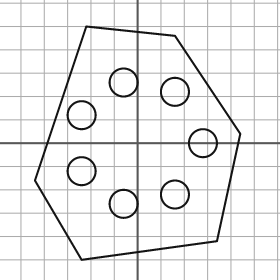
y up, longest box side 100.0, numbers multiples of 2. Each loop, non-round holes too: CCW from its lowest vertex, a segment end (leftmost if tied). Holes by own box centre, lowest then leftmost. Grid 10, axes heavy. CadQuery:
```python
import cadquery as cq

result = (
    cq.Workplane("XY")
    .moveTo(-24.0, -50.0)
    .lineTo(34.0, -42.0)
    .lineTo(44.0, 4.0)
    .lineTo(16.0, 46.0)
    .lineTo(-22.0, 50.0)
    .lineTo(-44.0, -16.0)
    .close()
    .moveTo(-6.0, -26.0)
    .circle(6.0)
    .moveTo(16.0, -22.0)
    .circle(6.0)
    .moveTo(-24.0, -12.0)
    .circle(6.0)
    .moveTo(28.0, 0.0)
    .circle(6.0)
    .moveTo(-24.0, 12.0)
    .circle(6.0)
    .moveTo(16.0, 22.0)
    .circle(6.0)
    .moveTo(-6.0, 26.0)
    .circle(6.0)
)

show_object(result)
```